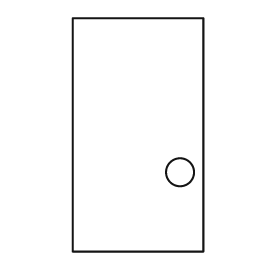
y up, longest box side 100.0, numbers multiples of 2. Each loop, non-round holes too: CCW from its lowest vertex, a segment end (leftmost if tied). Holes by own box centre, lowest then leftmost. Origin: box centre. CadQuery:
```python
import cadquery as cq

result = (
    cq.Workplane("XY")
    .moveTo(-28.0, -50.0)
    .lineTo(28.0, -50.0)
    .lineTo(28.0, 50.0)
    .lineTo(-28.0, 50.0)
    .close()
    .moveTo(18.0, -16.0)
    .circle(6.0)
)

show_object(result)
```